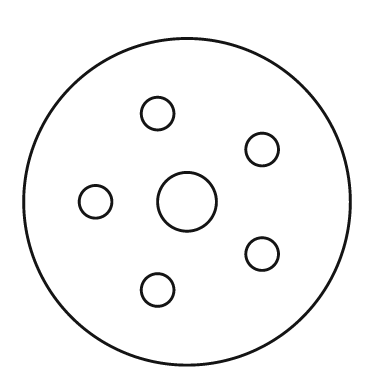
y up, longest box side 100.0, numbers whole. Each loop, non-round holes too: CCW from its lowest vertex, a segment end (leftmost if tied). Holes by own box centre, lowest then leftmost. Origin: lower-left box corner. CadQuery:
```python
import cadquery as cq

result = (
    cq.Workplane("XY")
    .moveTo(50.0, 50.0)
    .circle(50.0)
    .moveTo(41.0, 23.0)
    .circle(5.0)
    .moveTo(73.0, 34.0)
    .circle(5.0)
    .moveTo(22.0, 50.0)
    .circle(5.0)
    .moveTo(50.0, 50.0)
    .circle(9.0)
    .moveTo(73.0, 66.0)
    .circle(5.0)
    .moveTo(41.0, 77.0)
    .circle(5.0)
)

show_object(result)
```